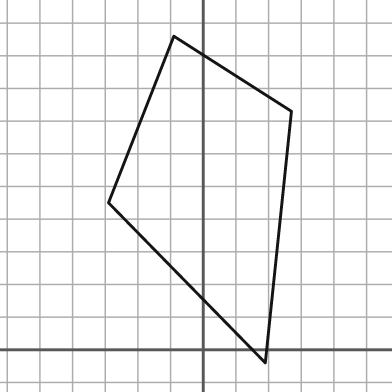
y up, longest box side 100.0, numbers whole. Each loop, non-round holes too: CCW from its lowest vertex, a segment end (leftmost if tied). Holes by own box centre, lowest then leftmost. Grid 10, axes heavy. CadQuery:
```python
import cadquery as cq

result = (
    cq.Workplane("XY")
    .moveTo(19.0, -4.0)
    .lineTo(27.0, 73.0)
    .lineTo(-9.0, 96.0)
    .lineTo(-29.0, 45.0)
    .close()
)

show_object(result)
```